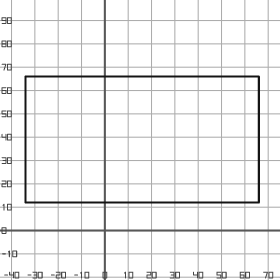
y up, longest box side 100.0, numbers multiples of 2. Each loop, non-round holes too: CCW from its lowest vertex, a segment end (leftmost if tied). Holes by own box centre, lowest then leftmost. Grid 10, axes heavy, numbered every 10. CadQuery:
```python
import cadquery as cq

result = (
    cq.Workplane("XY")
    .moveTo(-34.0, 12.0)
    .lineTo(66.0, 12.0)
    .lineTo(66.0, 66.0)
    .lineTo(-34.0, 66.0)
    .close()
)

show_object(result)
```